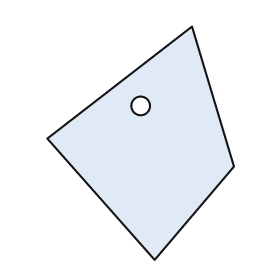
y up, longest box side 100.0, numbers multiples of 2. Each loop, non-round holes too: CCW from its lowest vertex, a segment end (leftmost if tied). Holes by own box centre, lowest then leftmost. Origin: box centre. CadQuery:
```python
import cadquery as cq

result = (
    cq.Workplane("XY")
    .moveTo(6.0, -50.0)
    .lineTo(40.0, -10.0)
    .lineTo(22.0, 50.0)
    .lineTo(-40.0, 2.0)
    .close()
    .moveTo(0.0, 16.0)
    .circle(4.0)
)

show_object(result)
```